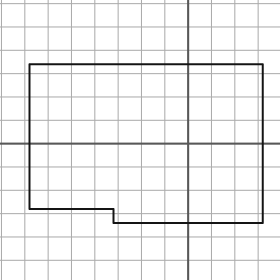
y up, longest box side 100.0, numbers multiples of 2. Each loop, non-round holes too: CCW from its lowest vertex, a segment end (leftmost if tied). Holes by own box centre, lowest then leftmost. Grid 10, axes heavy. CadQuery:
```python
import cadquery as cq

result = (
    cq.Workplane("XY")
    .moveTo(-32.0, -34.0)
    .lineTo(32.0, -34.0)
    .lineTo(32.0, 34.0)
    .lineTo(-68.0, 34.0)
    .lineTo(-68.0, -28.0)
    .lineTo(-32.0, -28.0)
    .close()
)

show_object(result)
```